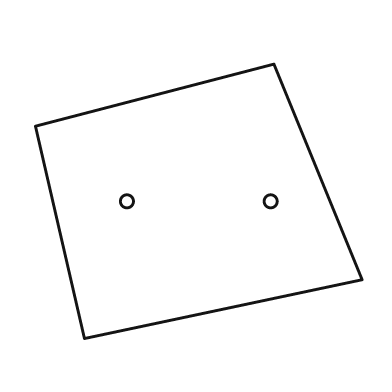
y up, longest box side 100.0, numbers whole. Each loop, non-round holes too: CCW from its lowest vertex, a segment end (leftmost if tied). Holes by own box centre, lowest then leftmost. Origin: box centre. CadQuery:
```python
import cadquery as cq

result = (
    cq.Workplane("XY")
    .moveTo(-35.0, -42.0)
    .lineTo(50.0, -24.0)
    .lineTo(23.0, 42.0)
    .lineTo(-50.0, 23.0)
    .close()
    .moveTo(-22.0, 0.0)
    .circle(2.0)
    .moveTo(22.0, 0.0)
    .circle(2.0)
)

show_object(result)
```